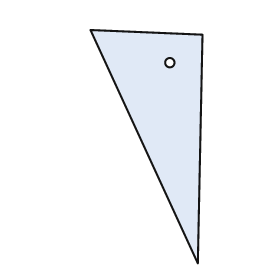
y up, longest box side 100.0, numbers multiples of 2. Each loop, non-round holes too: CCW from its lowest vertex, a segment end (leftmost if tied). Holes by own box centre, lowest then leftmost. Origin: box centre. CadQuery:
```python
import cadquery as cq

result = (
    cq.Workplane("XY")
    .moveTo(22.0, -50.0)
    .lineTo(24.0, 48.0)
    .lineTo(-24.0, 50.0)
    .close()
    .moveTo(10.0, 36.0)
    .circle(2.0)
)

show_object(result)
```